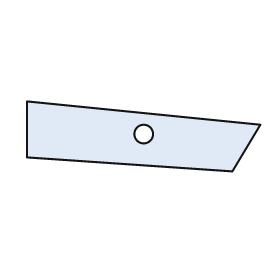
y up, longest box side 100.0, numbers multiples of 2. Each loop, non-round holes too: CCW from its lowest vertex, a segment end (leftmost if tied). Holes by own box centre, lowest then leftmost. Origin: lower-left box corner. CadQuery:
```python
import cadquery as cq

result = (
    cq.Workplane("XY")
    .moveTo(88.0, 0.0)
    .lineTo(100.0, 20.0)
    .lineTo(0.0, 30.0)
    .lineTo(0.0, 6.0)
    .close()
    .moveTo(50.0, 16.0)
    .circle(4.0)
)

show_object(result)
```